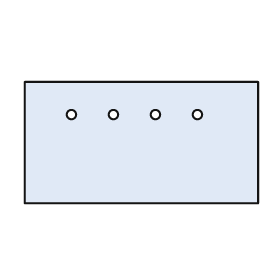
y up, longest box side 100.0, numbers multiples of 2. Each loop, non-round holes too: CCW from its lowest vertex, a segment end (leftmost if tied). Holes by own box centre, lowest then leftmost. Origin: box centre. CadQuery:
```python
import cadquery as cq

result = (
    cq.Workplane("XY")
    .moveTo(-50.0, -26.0)
    .lineTo(50.0, -26.0)
    .lineTo(50.0, 26.0)
    .lineTo(-50.0, 26.0)
    .close()
    .moveTo(-30.0, 12.0)
    .circle(2.0)
    .moveTo(-12.0, 12.0)
    .circle(2.0)
    .moveTo(6.0, 12.0)
    .circle(2.0)
    .moveTo(24.0, 12.0)
    .circle(2.0)
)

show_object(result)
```